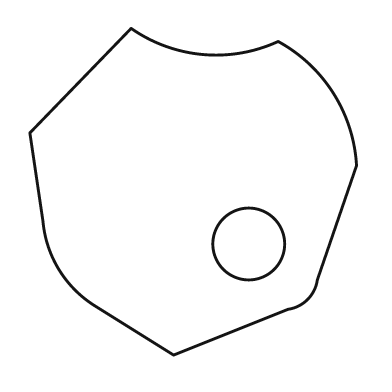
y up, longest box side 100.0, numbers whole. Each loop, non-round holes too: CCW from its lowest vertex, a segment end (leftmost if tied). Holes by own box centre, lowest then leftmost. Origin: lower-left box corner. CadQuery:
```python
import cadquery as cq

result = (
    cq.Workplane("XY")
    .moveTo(44.0, 0.0)
    .lineTo(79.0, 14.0)
    .threePointArc((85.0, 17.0), (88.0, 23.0))
    .lineTo(100.0, 58.0)
    .threePointArc((93.0, 80.0), (76.0, 96.0))
    .threePointArc((53.0, 92.0), (31.0, 100.0))
    .lineTo(0.0, 68.0)
    .lineTo(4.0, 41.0)
    .threePointArc((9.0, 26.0), (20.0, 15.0))
    .close()
    .moveTo(67.0, 34.0)
    .circle(11.0)
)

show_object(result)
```